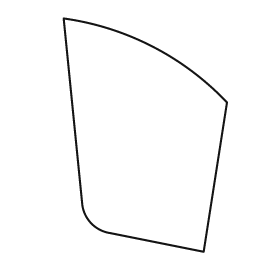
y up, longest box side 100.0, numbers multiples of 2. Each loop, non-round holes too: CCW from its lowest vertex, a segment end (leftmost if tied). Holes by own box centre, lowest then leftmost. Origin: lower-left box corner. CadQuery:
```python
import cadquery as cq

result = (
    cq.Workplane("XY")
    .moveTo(60.0, 0.0)
    .lineTo(70.0, 64.0)
    .threePointArc((38.0, 88.0), (0.0, 100.0))
    .lineTo(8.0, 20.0)
    .threePointArc((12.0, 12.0), (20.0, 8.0))
    .close()
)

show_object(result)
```